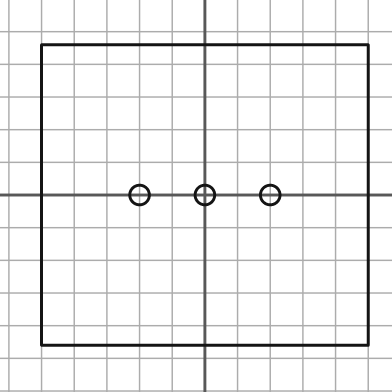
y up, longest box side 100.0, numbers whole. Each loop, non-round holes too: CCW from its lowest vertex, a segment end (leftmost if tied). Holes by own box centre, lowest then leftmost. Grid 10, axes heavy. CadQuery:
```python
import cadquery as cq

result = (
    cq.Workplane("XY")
    .moveTo(-50.0, -46.0)
    .lineTo(50.0, -46.0)
    .lineTo(50.0, 46.0)
    .lineTo(-50.0, 46.0)
    .close()
    .moveTo(-20.0, 0.0)
    .circle(3.0)
    .moveTo(0.0, 0.0)
    .circle(3.0)
    .moveTo(20.0, 0.0)
    .circle(3.0)
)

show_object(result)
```